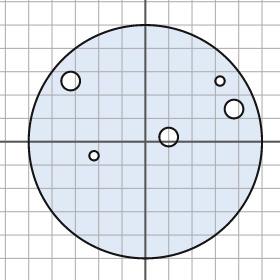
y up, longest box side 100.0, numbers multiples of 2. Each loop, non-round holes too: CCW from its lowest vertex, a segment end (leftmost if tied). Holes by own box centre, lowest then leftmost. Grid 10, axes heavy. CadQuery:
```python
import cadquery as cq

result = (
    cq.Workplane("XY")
    .moveTo(0.0, 0.0)
    .circle(50.0)
    .moveTo(-22.0, -6.0)
    .circle(2.0)
    .moveTo(10.0, 2.0)
    .circle(4.0)
    .moveTo(38.0, 14.0)
    .circle(4.0)
    .moveTo(-32.0, 26.0)
    .circle(4.0)
    .moveTo(32.0, 26.0)
    .circle(2.0)
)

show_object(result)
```